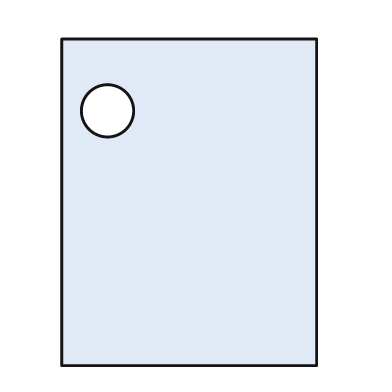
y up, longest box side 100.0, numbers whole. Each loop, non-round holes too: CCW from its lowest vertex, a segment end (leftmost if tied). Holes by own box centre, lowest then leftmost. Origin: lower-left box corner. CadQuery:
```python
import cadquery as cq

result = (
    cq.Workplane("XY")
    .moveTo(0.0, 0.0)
    .lineTo(78.0, 0.0)
    .lineTo(78.0, 100.0)
    .lineTo(0.0, 100.0)
    .close()
    .moveTo(14.0, 78.0)
    .circle(8.0)
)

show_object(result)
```